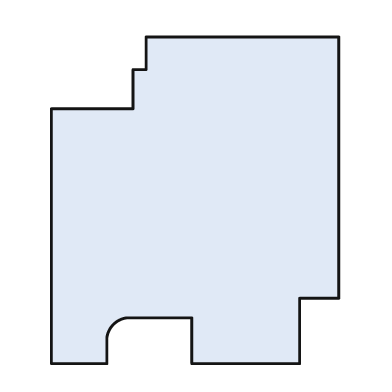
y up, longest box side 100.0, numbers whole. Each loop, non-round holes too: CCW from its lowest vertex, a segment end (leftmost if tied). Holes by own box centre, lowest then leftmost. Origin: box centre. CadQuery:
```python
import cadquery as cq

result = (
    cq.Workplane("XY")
    .moveTo(-44.0, -50.0)
    .lineTo(-27.0, -50.0)
    .lineTo(-27.0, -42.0)
    .threePointArc((-25.0, -38.0), (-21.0, -36.0))
    .lineTo(-1.0, -36.0)
    .lineTo(-1.0, -50.0)
    .lineTo(32.0, -50.0)
    .lineTo(32.0, -30.0)
    .lineTo(44.0, -30.0)
    .lineTo(44.0, 50.0)
    .lineTo(-15.0, 50.0)
    .lineTo(-15.0, 40.0)
    .lineTo(-19.0, 40.0)
    .lineTo(-19.0, 28.0)
    .lineTo(-44.0, 28.0)
    .close()
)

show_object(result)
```